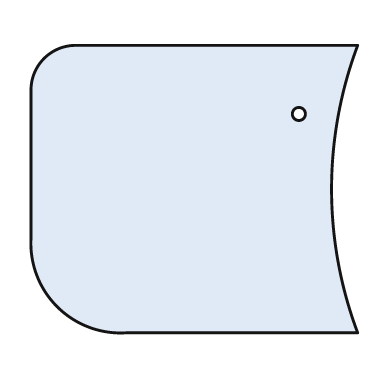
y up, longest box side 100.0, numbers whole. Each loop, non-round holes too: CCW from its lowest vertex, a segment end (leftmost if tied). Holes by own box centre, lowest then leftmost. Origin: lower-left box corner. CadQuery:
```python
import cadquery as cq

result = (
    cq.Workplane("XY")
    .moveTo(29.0, 0.0)
    .lineTo(100.0, 0.0)
    .threePointArc((92.0, 44.0), (100.0, 88.0))
    .lineTo(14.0, 88.0)
    .threePointArc((4.0, 84.0), (0.0, 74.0))
    .lineTo(0.0, 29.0)
    .threePointArc((8.0, 8.0), (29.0, 0.0))
    .close()
    .moveTo(82.0, 67.0)
    .circle(2.0)
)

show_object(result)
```